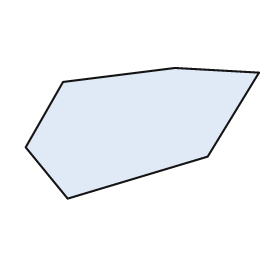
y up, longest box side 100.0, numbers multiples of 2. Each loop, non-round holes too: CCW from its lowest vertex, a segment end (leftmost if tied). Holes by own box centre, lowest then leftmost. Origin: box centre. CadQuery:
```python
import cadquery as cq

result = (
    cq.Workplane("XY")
    .moveTo(-32.0, -28.0)
    .lineTo(28.0, -10.0)
    .lineTo(50.0, 26.0)
    .lineTo(14.0, 28.0)
    .lineTo(-34.0, 22.0)
    .lineTo(-50.0, -6.0)
    .close()
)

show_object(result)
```